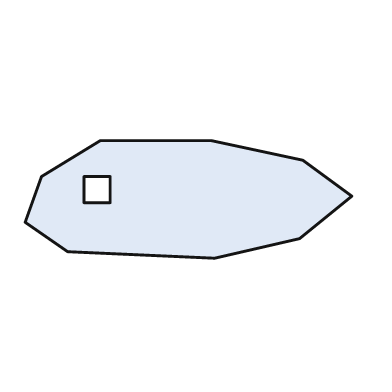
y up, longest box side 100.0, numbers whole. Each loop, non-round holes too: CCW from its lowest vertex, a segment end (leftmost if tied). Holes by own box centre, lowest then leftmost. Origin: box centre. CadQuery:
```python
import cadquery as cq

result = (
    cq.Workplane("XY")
    .moveTo(8.0, -18.0)
    .lineTo(34.0, -12.0)
    .lineTo(50.0, 1.0)
    .lineTo(35.0, 12.0)
    .lineTo(7.0, 18.0)
    .lineTo(-27.0, 18.0)
    .lineTo(-45.0, 7.0)
    .lineTo(-50.0, -7.0)
    .lineTo(-37.0, -16.0)
    .close()
    .moveTo(-32.0, -1.0)
    .lineTo(-24.0, -1.0)
    .lineTo(-24.0, 7.0)
    .lineTo(-32.0, 7.0)
    .close()
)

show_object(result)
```